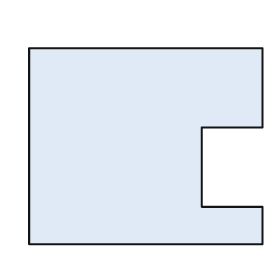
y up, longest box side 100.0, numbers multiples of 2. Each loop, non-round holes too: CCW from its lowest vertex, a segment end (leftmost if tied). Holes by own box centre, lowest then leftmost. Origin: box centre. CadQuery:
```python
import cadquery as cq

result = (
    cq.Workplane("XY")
    .moveTo(-50.0, -42.0)
    .lineTo(50.0, -42.0)
    .lineTo(50.0, -26.0)
    .lineTo(24.0, -26.0)
    .lineTo(24.0, 8.0)
    .lineTo(50.0, 8.0)
    .lineTo(50.0, 42.0)
    .lineTo(-50.0, 42.0)
    .close()
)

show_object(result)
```